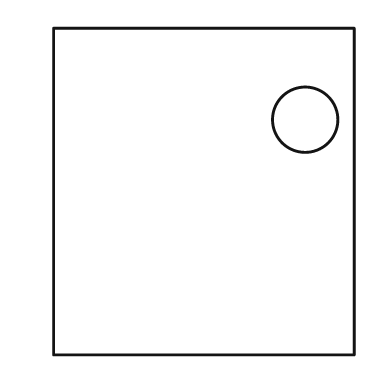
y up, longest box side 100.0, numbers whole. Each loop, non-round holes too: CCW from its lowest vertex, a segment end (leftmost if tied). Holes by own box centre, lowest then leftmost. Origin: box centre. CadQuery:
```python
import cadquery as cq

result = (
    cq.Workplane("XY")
    .moveTo(-46.0, -50.0)
    .lineTo(46.0, -50.0)
    .lineTo(46.0, 50.0)
    .lineTo(-46.0, 50.0)
    .close()
    .moveTo(31.0, 22.0)
    .circle(10.0)
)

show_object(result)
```